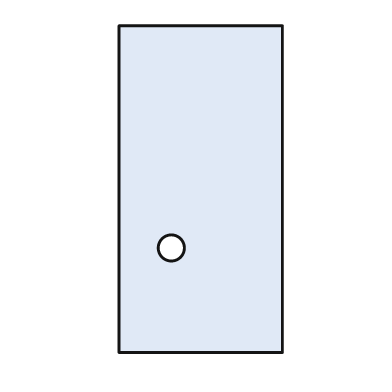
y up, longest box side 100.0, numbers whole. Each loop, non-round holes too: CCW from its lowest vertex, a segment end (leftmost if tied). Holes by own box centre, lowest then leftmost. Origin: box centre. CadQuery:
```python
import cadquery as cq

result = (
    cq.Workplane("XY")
    .moveTo(-25.0, -50.0)
    .lineTo(25.0, -50.0)
    .lineTo(25.0, 50.0)
    .lineTo(-25.0, 50.0)
    .close()
    .moveTo(-9.0, -18.0)
    .circle(4.0)
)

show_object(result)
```